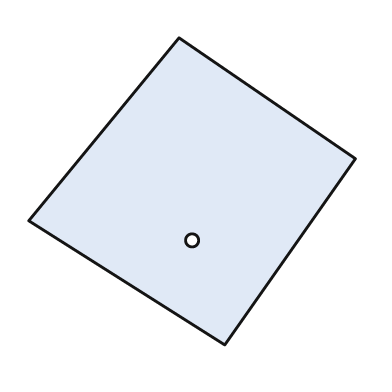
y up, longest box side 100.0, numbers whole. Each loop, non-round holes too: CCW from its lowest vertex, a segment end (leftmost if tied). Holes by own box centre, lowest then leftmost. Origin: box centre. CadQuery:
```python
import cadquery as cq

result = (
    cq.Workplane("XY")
    .moveTo(10.0, -47.0)
    .lineTo(50.0, 10.0)
    .lineTo(-4.0, 47.0)
    .lineTo(-50.0, -9.0)
    .close()
    .moveTo(0.0, -15.0)
    .circle(2.0)
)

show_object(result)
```